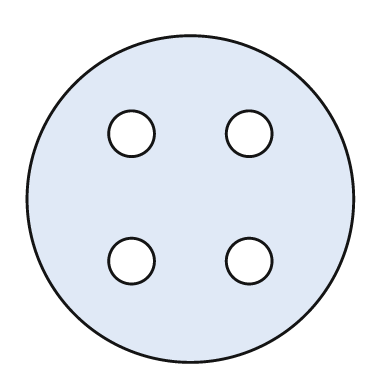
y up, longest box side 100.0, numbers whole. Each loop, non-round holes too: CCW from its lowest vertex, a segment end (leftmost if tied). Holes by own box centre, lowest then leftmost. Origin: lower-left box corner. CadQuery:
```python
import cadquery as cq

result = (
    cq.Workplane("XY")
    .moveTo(50.0, 50.0)
    .circle(50.0)
    .moveTo(32.0, 31.0)
    .circle(7.0)
    .moveTo(68.0, 31.0)
    .circle(7.0)
    .moveTo(32.0, 70.0)
    .circle(7.0)
    .moveTo(68.0, 70.0)
    .circle(7.0)
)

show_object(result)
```